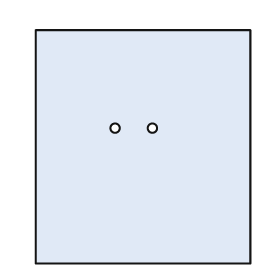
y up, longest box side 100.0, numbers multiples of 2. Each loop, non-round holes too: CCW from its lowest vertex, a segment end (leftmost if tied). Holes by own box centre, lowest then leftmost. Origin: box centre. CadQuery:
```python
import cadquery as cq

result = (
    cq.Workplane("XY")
    .moveTo(-46.0, -50.0)
    .lineTo(46.0, -50.0)
    .lineTo(46.0, 50.0)
    .lineTo(-46.0, 50.0)
    .close()
    .moveTo(-12.0, 8.0)
    .circle(2.0)
    .moveTo(4.0, 8.0)
    .circle(2.0)
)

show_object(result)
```